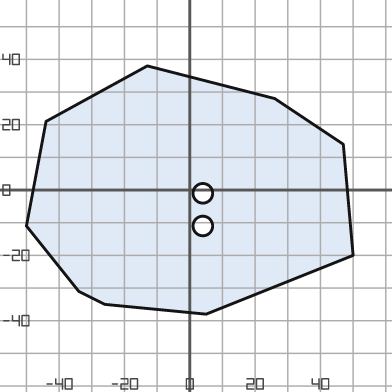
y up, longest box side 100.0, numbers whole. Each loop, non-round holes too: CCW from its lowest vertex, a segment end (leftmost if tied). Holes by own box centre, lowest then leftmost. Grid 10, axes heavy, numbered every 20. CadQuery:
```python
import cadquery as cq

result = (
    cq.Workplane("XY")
    .moveTo(5.0, -38.0)
    .lineTo(50.0, -20.0)
    .lineTo(47.0, 14.0)
    .lineTo(26.0, 28.0)
    .lineTo(-13.0, 38.0)
    .lineTo(-44.0, 21.0)
    .lineTo(-50.0, -11.0)
    .lineTo(-34.0, -31.0)
    .lineTo(-26.0, -35.0)
    .close()
    .moveTo(4.0, -11.0)
    .circle(3.0)
    .moveTo(4.0, -1.0)
    .circle(3.0)
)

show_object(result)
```